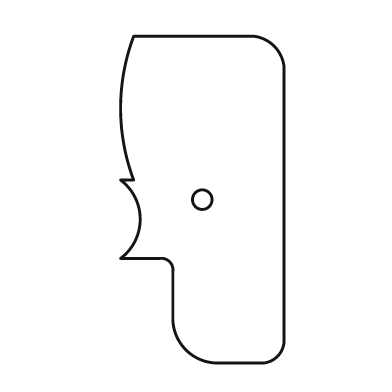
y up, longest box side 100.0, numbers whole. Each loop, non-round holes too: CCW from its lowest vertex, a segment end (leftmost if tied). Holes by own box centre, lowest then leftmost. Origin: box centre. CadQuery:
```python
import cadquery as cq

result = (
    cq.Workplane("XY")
    .moveTo(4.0, -50.0)
    .lineTo(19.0, -50.0)
    .threePointArc((23.0, -48.0), (25.0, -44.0))
    .lineTo(25.0, 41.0)
    .threePointArc((22.0, 47.0), (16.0, 50.0))
    .lineTo(-21.0, 50.0)
    .threePointArc((-25.0, 28.0), (-21.0, 6.0))
    .lineTo(-25.0, 6.0)
    .threePointArc((-19.0, -6.0), (-25.0, -18.0))
    .lineTo(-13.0, -18.0)
    .threePointArc((-10.0, -19.0), (-9.0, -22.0))
    .lineTo(-9.0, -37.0)
    .threePointArc((-5.0, -46.0), (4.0, -50.0))
    .close()
    .moveTo(0.0, 0.0)
    .circle(3.0)
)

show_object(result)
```